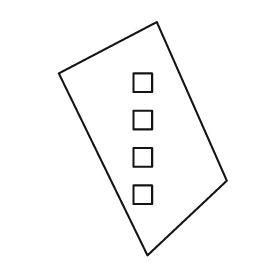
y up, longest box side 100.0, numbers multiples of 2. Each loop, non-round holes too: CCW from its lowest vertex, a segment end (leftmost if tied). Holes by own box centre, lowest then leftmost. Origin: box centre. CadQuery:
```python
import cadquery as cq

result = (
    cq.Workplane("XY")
    .moveTo(2.0, -50.0)
    .lineTo(36.0, -18.0)
    .lineTo(6.0, 50.0)
    .lineTo(-36.0, 28.0)
    .close()
    .moveTo(-4.0, -28.0)
    .lineTo(4.0, -28.0)
    .lineTo(4.0, -20.0)
    .lineTo(-4.0, -20.0)
    .close()
    .moveTo(-4.0, -12.0)
    .lineTo(4.0, -12.0)
    .lineTo(4.0, -4.0)
    .lineTo(-4.0, -4.0)
    .close()
    .moveTo(-4.0, 4.0)
    .lineTo(4.0, 4.0)
    .lineTo(4.0, 12.0)
    .lineTo(-4.0, 12.0)
    .close()
    .moveTo(-4.0, 20.0)
    .lineTo(4.0, 20.0)
    .lineTo(4.0, 28.0)
    .lineTo(-4.0, 28.0)
    .close()
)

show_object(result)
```